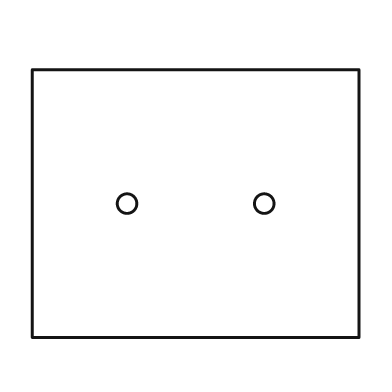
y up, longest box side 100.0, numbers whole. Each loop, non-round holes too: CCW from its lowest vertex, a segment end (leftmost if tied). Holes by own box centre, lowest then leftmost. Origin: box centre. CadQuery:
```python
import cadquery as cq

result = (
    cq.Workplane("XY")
    .moveTo(-50.0, -41.0)
    .lineTo(50.0, -41.0)
    .lineTo(50.0, 41.0)
    .lineTo(-50.0, 41.0)
    .close()
    .moveTo(-21.0, 0.0)
    .circle(3.0)
    .moveTo(21.0, 0.0)
    .circle(3.0)
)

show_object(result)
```